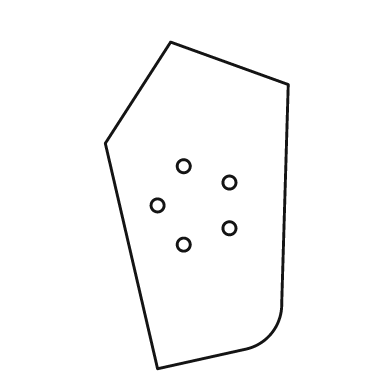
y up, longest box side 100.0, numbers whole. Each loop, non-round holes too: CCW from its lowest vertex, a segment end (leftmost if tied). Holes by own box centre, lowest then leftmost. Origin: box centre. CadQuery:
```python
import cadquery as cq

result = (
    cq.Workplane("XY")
    .moveTo(-12.0, -50.0)
    .lineTo(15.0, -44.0)
    .threePointArc((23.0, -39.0), (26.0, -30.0))
    .lineTo(28.0, 37.0)
    .lineTo(-8.0, 50.0)
    .lineTo(-28.0, 19.0)
    .close()
    .moveTo(-4.0, -12.0)
    .circle(2.0)
    .moveTo(10.0, -7.0)
    .circle(2.0)
    .moveTo(-12.0, 0.0)
    .circle(2.0)
    .moveTo(10.0, 7.0)
    .circle(2.0)
    .moveTo(-4.0, 12.0)
    .circle(2.0)
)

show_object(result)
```